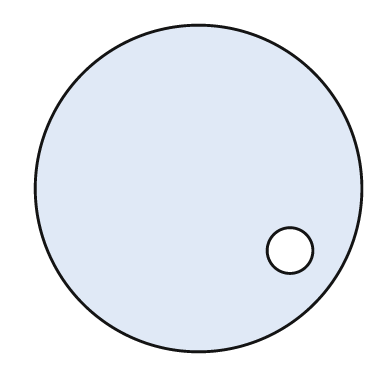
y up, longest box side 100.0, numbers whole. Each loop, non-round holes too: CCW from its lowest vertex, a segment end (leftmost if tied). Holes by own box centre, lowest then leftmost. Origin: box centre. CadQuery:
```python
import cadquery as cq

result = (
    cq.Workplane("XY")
    .moveTo(0.0, 0.0)
    .circle(50.0)
    .moveTo(28.0, -19.0)
    .circle(7.0)
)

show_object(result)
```